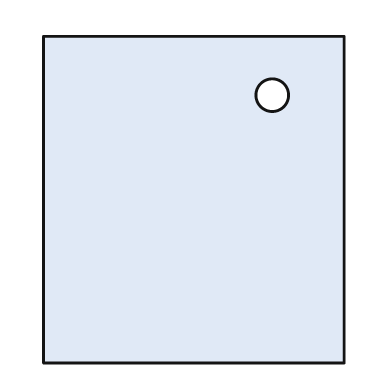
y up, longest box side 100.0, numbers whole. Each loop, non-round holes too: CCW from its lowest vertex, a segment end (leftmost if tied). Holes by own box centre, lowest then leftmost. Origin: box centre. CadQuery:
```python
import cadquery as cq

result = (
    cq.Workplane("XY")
    .moveTo(-46.0, -50.0)
    .lineTo(46.0, -50.0)
    .lineTo(46.0, 50.0)
    .lineTo(-46.0, 50.0)
    .close()
    .moveTo(24.0, 32.0)
    .circle(5.0)
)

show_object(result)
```